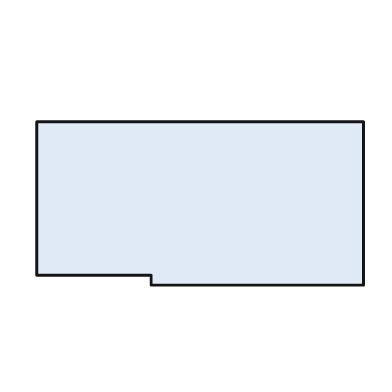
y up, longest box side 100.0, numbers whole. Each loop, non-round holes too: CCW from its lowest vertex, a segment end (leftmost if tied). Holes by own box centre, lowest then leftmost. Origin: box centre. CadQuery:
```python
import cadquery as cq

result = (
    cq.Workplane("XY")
    .moveTo(-15.0, -25.0)
    .lineTo(50.0, -25.0)
    .lineTo(50.0, 25.0)
    .lineTo(-50.0, 25.0)
    .lineTo(-50.0, -22.0)
    .lineTo(-15.0, -22.0)
    .close()
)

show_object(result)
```